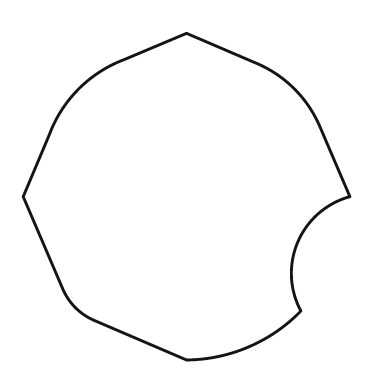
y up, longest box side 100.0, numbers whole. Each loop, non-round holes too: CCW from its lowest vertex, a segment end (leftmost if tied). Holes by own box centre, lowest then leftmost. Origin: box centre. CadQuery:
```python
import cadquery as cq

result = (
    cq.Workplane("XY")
    .moveTo(0.0, -50.0)
    .threePointArc((19.0, -46.0), (35.0, -35.0))
    .threePointArc((34.0, -14.0), (50.0, 0.0))
    .lineTo(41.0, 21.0)
    .threePointArc((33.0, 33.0), (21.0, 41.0))
    .lineTo(0.0, 50.0)
    .lineTo(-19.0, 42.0)
    .threePointArc((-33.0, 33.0), (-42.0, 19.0))
    .lineTo(-50.0, 0.0)
    .lineTo(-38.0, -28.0)
    .threePointArc((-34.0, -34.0), (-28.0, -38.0))
    .close()
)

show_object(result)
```